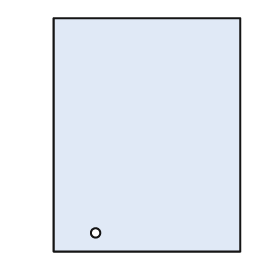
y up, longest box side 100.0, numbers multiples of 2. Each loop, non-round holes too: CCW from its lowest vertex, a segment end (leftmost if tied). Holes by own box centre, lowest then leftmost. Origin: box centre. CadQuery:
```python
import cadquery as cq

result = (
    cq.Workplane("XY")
    .moveTo(-40.0, -50.0)
    .lineTo(40.0, -50.0)
    .lineTo(40.0, 50.0)
    .lineTo(-40.0, 50.0)
    .close()
    .moveTo(-22.0, -42.0)
    .circle(2.0)
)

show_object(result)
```